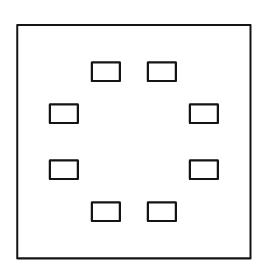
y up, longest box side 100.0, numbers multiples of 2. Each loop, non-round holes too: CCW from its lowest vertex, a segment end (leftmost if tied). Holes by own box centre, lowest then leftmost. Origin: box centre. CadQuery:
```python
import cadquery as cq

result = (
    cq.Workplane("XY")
    .moveTo(-50.0, -50.0)
    .lineTo(50.0, -50.0)
    .lineTo(50.0, 50.0)
    .lineTo(-50.0, 50.0)
    .close()
    .moveTo(-18.0, -34.0)
    .lineTo(-6.0, -34.0)
    .lineTo(-6.0, -26.0)
    .lineTo(-18.0, -26.0)
    .close()
    .moveTo(6.0, -34.0)
    .lineTo(18.0, -34.0)
    .lineTo(18.0, -26.0)
    .lineTo(6.0, -26.0)
    .close()
    .moveTo(-36.0, -16.0)
    .lineTo(-24.0, -16.0)
    .lineTo(-24.0, -8.0)
    .lineTo(-36.0, -8.0)
    .close()
    .moveTo(24.0, -16.0)
    .lineTo(36.0, -16.0)
    .lineTo(36.0, -8.0)
    .lineTo(24.0, -8.0)
    .close()
    .moveTo(-36.0, 8.0)
    .lineTo(-24.0, 8.0)
    .lineTo(-24.0, 16.0)
    .lineTo(-36.0, 16.0)
    .close()
    .moveTo(24.0, 8.0)
    .lineTo(36.0, 8.0)
    .lineTo(36.0, 16.0)
    .lineTo(24.0, 16.0)
    .close()
    .moveTo(-18.0, 26.0)
    .lineTo(-6.0, 26.0)
    .lineTo(-6.0, 34.0)
    .lineTo(-18.0, 34.0)
    .close()
    .moveTo(6.0, 26.0)
    .lineTo(18.0, 26.0)
    .lineTo(18.0, 34.0)
    .lineTo(6.0, 34.0)
    .close()
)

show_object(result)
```